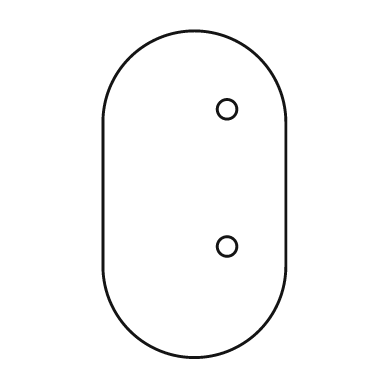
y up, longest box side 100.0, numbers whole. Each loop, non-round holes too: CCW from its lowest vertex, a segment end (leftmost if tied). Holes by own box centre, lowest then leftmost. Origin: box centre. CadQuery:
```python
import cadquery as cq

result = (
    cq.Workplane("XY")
    .moveTo(-28.0, -22.0)
    .threePointArc((0.0, -50.0), (28.0, -22.0))
    .lineTo(28.0, 22.0)
    .threePointArc((0.0, 50.0), (-28.0, 22.0))
    .close()
    .moveTo(10.0, -16.0)
    .circle(3.0)
    .moveTo(10.0, 26.0)
    .circle(3.0)
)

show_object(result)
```